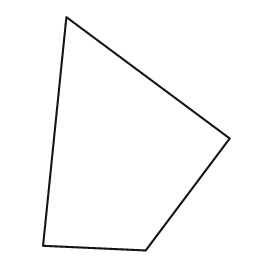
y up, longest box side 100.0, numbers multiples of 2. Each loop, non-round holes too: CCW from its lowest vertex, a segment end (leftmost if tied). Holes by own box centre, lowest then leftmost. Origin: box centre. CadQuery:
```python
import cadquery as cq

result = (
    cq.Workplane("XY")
    .moveTo(4.0, -50.0)
    .lineTo(40.0, -2.0)
    .lineTo(-30.0, 50.0)
    .lineTo(-40.0, -48.0)
    .close()
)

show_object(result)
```